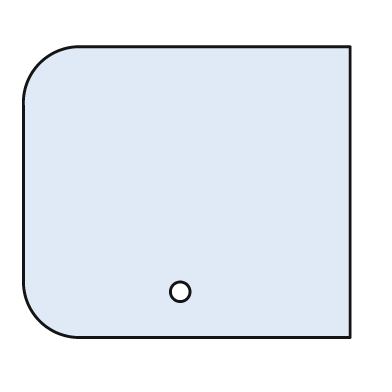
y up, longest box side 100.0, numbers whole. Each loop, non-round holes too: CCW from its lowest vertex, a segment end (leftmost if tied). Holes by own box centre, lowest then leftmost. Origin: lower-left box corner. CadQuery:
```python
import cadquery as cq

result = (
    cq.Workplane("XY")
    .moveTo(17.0, 0.0)
    .lineTo(100.0, 0.0)
    .lineTo(100.0, 89.0)
    .lineTo(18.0, 89.0)
    .threePointArc((5.0, 84.0), (0.0, 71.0))
    .lineTo(0.0, 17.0)
    .threePointArc((5.0, 5.0), (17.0, 0.0))
    .close()
    .moveTo(48.0, 14.0)
    .circle(3.0)
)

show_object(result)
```